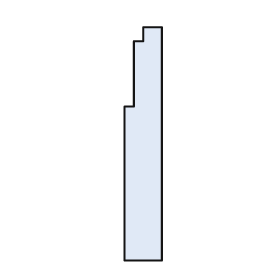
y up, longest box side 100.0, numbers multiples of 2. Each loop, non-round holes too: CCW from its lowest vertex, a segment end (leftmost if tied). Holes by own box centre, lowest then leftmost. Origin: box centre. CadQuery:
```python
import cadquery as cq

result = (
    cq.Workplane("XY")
    .moveTo(-8.0, -50.0)
    .lineTo(8.0, -50.0)
    .lineTo(8.0, 50.0)
    .lineTo(0.0, 50.0)
    .lineTo(0.0, 44.0)
    .lineTo(-4.0, 44.0)
    .lineTo(-4.0, 16.0)
    .lineTo(-8.0, 16.0)
    .close()
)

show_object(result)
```